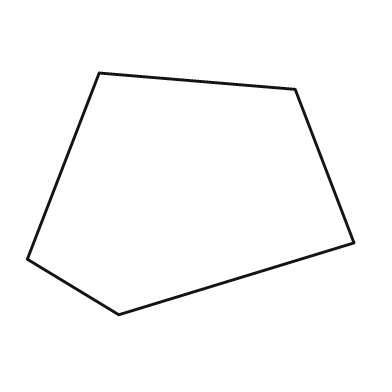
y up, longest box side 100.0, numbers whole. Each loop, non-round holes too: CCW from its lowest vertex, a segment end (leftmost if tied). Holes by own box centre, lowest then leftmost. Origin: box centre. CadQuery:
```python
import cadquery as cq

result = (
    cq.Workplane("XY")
    .moveTo(-22.0, -37.0)
    .lineTo(50.0, -15.0)
    .lineTo(32.0, 32.0)
    .lineTo(-28.0, 37.0)
    .lineTo(-50.0, -20.0)
    .close()
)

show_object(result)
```